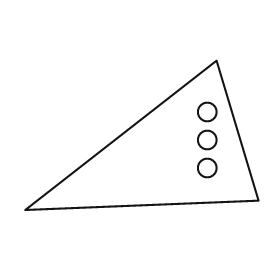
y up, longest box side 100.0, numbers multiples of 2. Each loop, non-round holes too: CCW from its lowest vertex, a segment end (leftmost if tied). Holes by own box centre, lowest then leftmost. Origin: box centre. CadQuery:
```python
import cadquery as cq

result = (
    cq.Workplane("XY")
    .moveTo(-50.0, -32.0)
    .lineTo(50.0, -28.0)
    .lineTo(32.0, 32.0)
    .close()
    .moveTo(28.0, -14.0)
    .circle(4.0)
    .moveTo(28.0, -2.0)
    .circle(4.0)
    .moveTo(28.0, 10.0)
    .circle(4.0)
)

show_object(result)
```